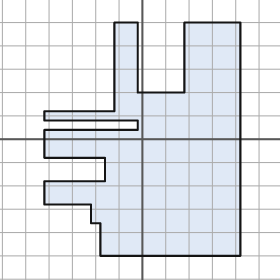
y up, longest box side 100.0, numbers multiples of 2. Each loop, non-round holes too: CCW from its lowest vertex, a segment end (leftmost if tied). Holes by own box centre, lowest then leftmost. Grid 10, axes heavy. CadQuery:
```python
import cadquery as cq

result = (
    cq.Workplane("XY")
    .moveTo(-18.0, -50.0)
    .lineTo(42.0, -50.0)
    .lineTo(42.0, 50.0)
    .lineTo(18.0, 50.0)
    .lineTo(18.0, 20.0)
    .lineTo(-2.0, 20.0)
    .lineTo(-2.0, 50.0)
    .lineTo(-12.0, 50.0)
    .lineTo(-12.0, 12.0)
    .lineTo(-42.0, 12.0)
    .lineTo(-42.0, 8.0)
    .lineTo(-2.0, 8.0)
    .lineTo(-2.0, 4.0)
    .lineTo(-42.0, 4.0)
    .lineTo(-42.0, -8.0)
    .lineTo(-16.0, -8.0)
    .lineTo(-16.0, -18.0)
    .lineTo(-42.0, -18.0)
    .lineTo(-42.0, -28.0)
    .lineTo(-22.0, -28.0)
    .lineTo(-22.0, -36.0)
    .lineTo(-18.0, -36.0)
    .close()
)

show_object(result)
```